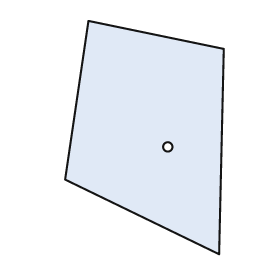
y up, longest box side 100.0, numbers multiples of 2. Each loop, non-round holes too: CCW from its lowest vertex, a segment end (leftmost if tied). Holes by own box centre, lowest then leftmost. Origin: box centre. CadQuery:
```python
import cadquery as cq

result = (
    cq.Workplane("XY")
    .moveTo(32.0, -50.0)
    .lineTo(34.0, 38.0)
    .lineTo(-24.0, 50.0)
    .lineTo(-34.0, -18.0)
    .close()
    .moveTo(10.0, -4.0)
    .circle(2.0)
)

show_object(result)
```